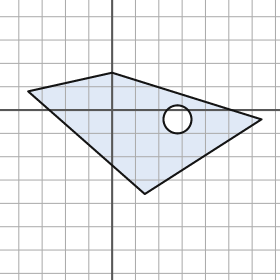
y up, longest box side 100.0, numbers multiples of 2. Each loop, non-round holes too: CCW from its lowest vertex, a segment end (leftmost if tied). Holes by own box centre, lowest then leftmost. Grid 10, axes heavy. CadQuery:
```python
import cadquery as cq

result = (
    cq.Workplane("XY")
    .moveTo(14.0, -36.0)
    .lineTo(64.0, -4.0)
    .lineTo(0.0, 16.0)
    .lineTo(-36.0, 8.0)
    .close()
    .moveTo(28.0, -4.0)
    .circle(6.0)
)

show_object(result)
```